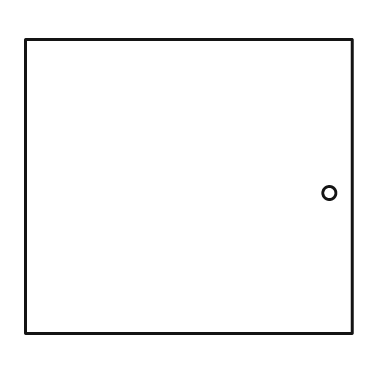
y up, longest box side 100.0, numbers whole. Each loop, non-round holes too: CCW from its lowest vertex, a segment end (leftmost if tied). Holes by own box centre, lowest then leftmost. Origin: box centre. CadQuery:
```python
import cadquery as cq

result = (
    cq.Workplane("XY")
    .moveTo(-50.0, -45.0)
    .lineTo(50.0, -45.0)
    .lineTo(50.0, 45.0)
    .lineTo(-50.0, 45.0)
    .close()
    .moveTo(43.0, -2.0)
    .circle(2.0)
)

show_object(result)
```